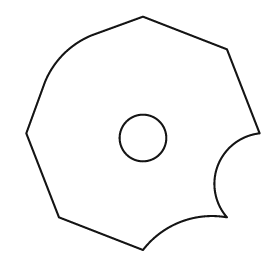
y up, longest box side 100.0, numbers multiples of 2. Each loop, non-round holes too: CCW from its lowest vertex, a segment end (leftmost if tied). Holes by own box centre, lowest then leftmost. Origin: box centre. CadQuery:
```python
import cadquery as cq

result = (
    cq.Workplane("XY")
    .moveTo(0.0, -50.0)
    .threePointArc((16.0, -38.0), (36.0, -36.0))
    .threePointArc((32.0, -14.0), (50.0, 0.0))
    .lineTo(36.0, 36.0)
    .lineTo(0.0, 50.0)
    .lineTo(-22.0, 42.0)
    .threePointArc((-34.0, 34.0), (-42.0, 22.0))
    .lineTo(-50.0, 0.0)
    .lineTo(-36.0, -36.0)
    .close()
    .moveTo(0.0, -2.0)
    .circle(10.0)
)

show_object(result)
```